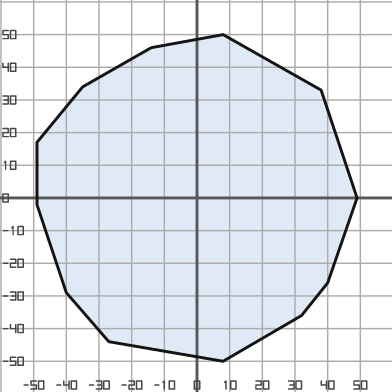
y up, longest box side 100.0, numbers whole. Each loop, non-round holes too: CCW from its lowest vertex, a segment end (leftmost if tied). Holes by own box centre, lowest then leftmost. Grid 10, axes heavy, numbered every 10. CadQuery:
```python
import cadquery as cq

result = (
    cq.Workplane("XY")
    .moveTo(8.0, -50.0)
    .lineTo(32.0, -36.0)
    .lineTo(40.0, -26.0)
    .lineTo(49.0, 0.0)
    .lineTo(38.0, 33.0)
    .lineTo(8.0, 50.0)
    .lineTo(-14.0, 46.0)
    .lineTo(-35.0, 34.0)
    .lineTo(-49.0, 17.0)
    .lineTo(-49.0, -2.0)
    .lineTo(-40.0, -29.0)
    .lineTo(-27.0, -44.0)
    .close()
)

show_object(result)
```